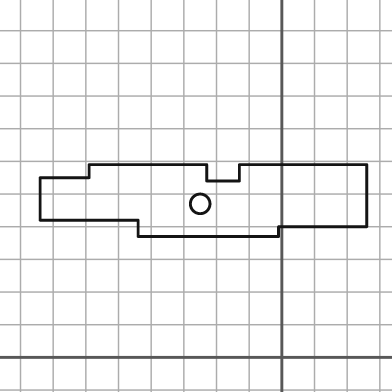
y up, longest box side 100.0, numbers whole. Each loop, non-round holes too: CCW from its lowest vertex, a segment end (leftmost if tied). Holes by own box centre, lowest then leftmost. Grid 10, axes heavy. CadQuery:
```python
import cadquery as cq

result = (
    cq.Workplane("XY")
    .moveTo(-44.0, 37.0)
    .lineTo(-1.0, 37.0)
    .lineTo(-1.0, 40.0)
    .lineTo(26.0, 40.0)
    .lineTo(26.0, 59.0)
    .lineTo(-13.0, 59.0)
    .lineTo(-13.0, 54.0)
    .lineTo(-23.0, 54.0)
    .lineTo(-23.0, 59.0)
    .lineTo(-59.0, 59.0)
    .lineTo(-59.0, 55.0)
    .lineTo(-74.0, 55.0)
    .lineTo(-74.0, 42.0)
    .lineTo(-44.0, 42.0)
    .close()
    .moveTo(-25.0, 47.0)
    .circle(3.0)
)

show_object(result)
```